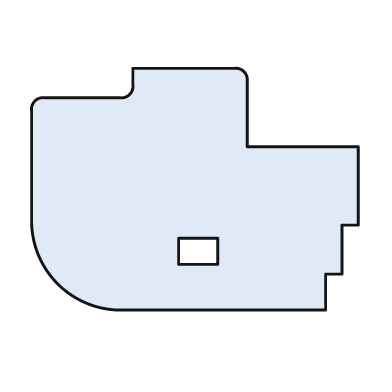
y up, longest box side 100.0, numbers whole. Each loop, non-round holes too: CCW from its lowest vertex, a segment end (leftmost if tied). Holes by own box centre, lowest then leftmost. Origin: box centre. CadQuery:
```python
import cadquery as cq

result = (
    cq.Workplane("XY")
    .moveTo(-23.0, -37.0)
    .lineTo(40.0, -37.0)
    .lineTo(40.0, -26.0)
    .lineTo(45.0, -26.0)
    .lineTo(45.0, -11.0)
    .lineTo(50.0, -11.0)
    .lineTo(50.0, 13.0)
    .lineTo(16.0, 13.0)
    .lineTo(16.0, 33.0)
    .threePointArc((15.0, 36.0), (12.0, 37.0))
    .lineTo(-19.0, 37.0)
    .lineTo(-19.0, 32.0)
    .threePointArc((-20.0, 29.0), (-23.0, 28.0))
    .lineTo(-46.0, 28.0)
    .threePointArc((-49.0, 27.0), (-50.0, 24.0))
    .lineTo(-50.0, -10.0)
    .threePointArc((-42.0, -29.0), (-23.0, -37.0))
    .close()
    .moveTo(-5.0, -23.0)
    .lineTo(7.0, -23.0)
    .lineTo(7.0, -15.0)
    .lineTo(-5.0, -15.0)
    .close()
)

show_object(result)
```